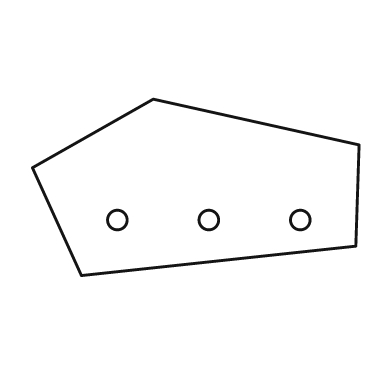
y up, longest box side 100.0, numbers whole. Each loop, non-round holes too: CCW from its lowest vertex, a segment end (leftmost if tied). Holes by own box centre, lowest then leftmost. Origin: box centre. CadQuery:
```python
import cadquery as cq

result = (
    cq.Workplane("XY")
    .moveTo(-35.0, -27.0)
    .lineTo(49.0, -18.0)
    .lineTo(50.0, 13.0)
    .lineTo(-13.0, 27.0)
    .lineTo(-50.0, 6.0)
    .close()
    .moveTo(-24.0, -10.0)
    .circle(3.0)
    .moveTo(4.0, -10.0)
    .circle(3.0)
    .moveTo(32.0, -10.0)
    .circle(3.0)
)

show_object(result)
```